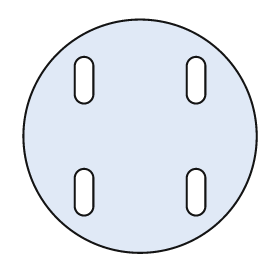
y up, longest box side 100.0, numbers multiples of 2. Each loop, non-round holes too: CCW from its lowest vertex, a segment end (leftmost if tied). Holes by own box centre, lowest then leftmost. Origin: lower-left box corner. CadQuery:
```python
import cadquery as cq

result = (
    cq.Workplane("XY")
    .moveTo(50.0, 50.0)
    .circle(50.0)
    .moveTo(22.0, 20.0)
    .threePointArc((26.0, 16.0), (30.0, 20.0))
    .lineTo(30.0, 32.0)
    .threePointArc((26.0, 36.0), (22.0, 32.0))
    .close()
    .moveTo(70.0, 20.0)
    .threePointArc((74.0, 16.0), (78.0, 20.0))
    .lineTo(78.0, 32.0)
    .threePointArc((74.0, 36.0), (70.0, 32.0))
    .close()
    .moveTo(22.0, 68.0)
    .threePointArc((26.0, 64.0), (30.0, 68.0))
    .lineTo(30.0, 80.0)
    .threePointArc((26.0, 84.0), (22.0, 80.0))
    .close()
    .moveTo(70.0, 68.0)
    .threePointArc((74.0, 64.0), (78.0, 68.0))
    .lineTo(78.0, 80.0)
    .threePointArc((74.0, 84.0), (70.0, 80.0))
    .close()
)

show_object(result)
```